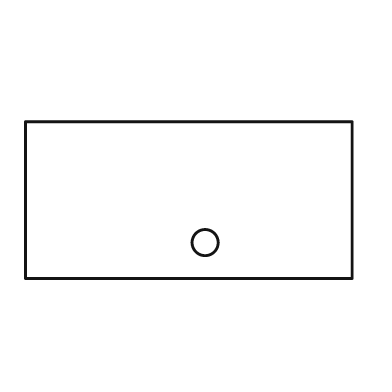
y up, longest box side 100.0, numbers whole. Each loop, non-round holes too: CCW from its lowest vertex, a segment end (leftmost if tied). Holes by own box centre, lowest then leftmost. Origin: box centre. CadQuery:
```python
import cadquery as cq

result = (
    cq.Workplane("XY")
    .moveTo(-50.0, -24.0)
    .lineTo(50.0, -24.0)
    .lineTo(50.0, 24.0)
    .lineTo(-50.0, 24.0)
    .close()
    .moveTo(5.0, -13.0)
    .circle(4.0)
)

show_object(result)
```